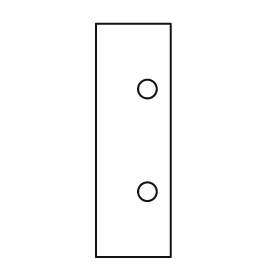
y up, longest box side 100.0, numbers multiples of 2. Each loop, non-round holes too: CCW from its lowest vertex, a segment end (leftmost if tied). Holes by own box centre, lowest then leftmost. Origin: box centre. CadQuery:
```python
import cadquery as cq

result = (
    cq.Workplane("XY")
    .moveTo(-16.0, -50.0)
    .lineTo(16.0, -50.0)
    .lineTo(16.0, 50.0)
    .lineTo(-16.0, 50.0)
    .close()
    .moveTo(6.0, -22.0)
    .circle(4.0)
    .moveTo(6.0, 22.0)
    .circle(4.0)
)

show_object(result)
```